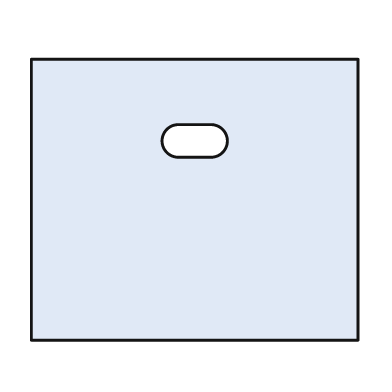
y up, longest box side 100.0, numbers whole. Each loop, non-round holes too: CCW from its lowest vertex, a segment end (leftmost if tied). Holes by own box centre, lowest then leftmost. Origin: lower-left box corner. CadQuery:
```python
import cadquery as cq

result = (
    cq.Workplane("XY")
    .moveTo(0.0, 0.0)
    .lineTo(100.0, 0.0)
    .lineTo(100.0, 86.0)
    .lineTo(0.0, 86.0)
    .close()
    .moveTo(45.0, 56.0)
    .lineTo(55.0, 56.0)
    .threePointArc((60.0, 61.0), (55.0, 66.0))
    .lineTo(45.0, 66.0)
    .threePointArc((40.0, 61.0), (45.0, 56.0))
    .close()
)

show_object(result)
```